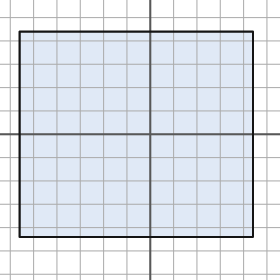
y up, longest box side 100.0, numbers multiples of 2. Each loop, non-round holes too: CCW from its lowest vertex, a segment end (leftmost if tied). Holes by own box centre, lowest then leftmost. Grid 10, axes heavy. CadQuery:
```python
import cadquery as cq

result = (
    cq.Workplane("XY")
    .moveTo(-56.0, -44.0)
    .lineTo(44.0, -44.0)
    .lineTo(44.0, 44.0)
    .lineTo(-56.0, 44.0)
    .close()
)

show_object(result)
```